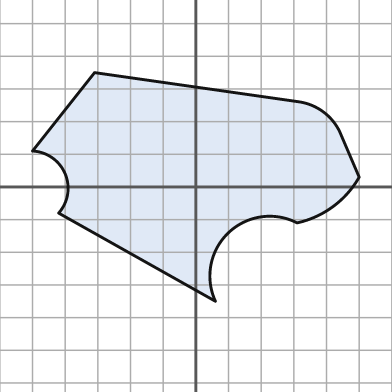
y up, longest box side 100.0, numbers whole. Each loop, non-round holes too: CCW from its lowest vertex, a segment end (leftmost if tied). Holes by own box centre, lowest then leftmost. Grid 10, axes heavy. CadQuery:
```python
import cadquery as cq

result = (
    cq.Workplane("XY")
    .moveTo(6.0, -35.0)
    .threePointArc((10.0, -14.0), (31.0, -11.0))
    .threePointArc((42.0, -6.0), (50.0, 3.0))
    .lineTo(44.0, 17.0)
    .threePointArc((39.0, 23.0), (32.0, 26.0))
    .lineTo(-31.0, 35.0)
    .lineTo(-50.0, 11.0)
    .threePointArc((-40.0, 4.0), (-42.0, -8.0))
    .close()
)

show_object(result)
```